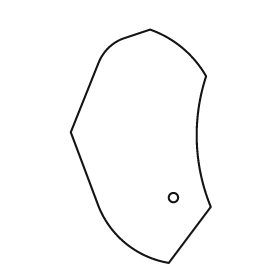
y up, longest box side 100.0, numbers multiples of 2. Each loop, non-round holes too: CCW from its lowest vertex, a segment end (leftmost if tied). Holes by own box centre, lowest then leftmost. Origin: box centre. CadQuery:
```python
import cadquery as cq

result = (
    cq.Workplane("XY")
    .moveTo(12.0, -50.0)
    .lineTo(30.0, -26.0)
    .threePointArc((24.0, 2.0), (28.0, 30.0))
    .threePointArc((18.0, 42.0), (4.0, 50.0))
    .lineTo(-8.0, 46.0)
    .threePointArc((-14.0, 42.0), (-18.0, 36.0))
    .lineTo(-30.0, 6.0)
    .lineTo(-18.0, -26.0)
    .threePointArc((-6.0, -42.0), (12.0, -50.0))
    .close()
    .moveTo(14.0, -22.0)
    .circle(2.0)
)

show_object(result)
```